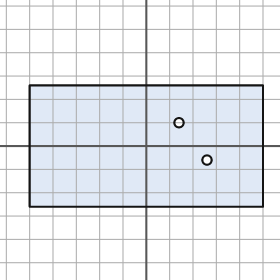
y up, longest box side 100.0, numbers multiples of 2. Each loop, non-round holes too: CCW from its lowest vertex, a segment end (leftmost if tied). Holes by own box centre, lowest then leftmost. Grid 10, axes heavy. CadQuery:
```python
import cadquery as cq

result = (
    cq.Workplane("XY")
    .moveTo(-50.0, -26.0)
    .lineTo(50.0, -26.0)
    .lineTo(50.0, 26.0)
    .lineTo(-50.0, 26.0)
    .close()
    .moveTo(26.0, -6.0)
    .circle(2.0)
    .moveTo(14.0, 10.0)
    .circle(2.0)
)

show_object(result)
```